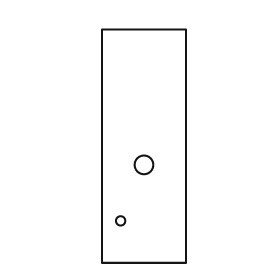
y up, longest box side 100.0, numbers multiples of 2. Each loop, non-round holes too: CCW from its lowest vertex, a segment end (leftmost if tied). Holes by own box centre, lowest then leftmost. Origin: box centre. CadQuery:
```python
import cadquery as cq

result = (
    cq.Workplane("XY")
    .moveTo(-18.0, -50.0)
    .lineTo(18.0, -50.0)
    .lineTo(18.0, 50.0)
    .lineTo(-18.0, 50.0)
    .close()
    .moveTo(-10.0, -32.0)
    .circle(2.0)
    .moveTo(0.0, -8.0)
    .circle(4.0)
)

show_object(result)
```